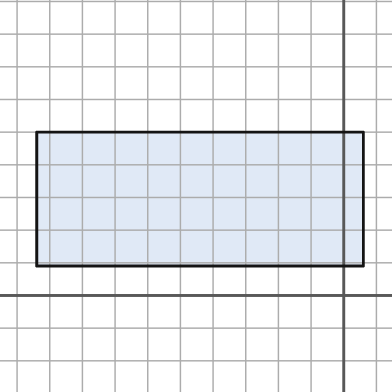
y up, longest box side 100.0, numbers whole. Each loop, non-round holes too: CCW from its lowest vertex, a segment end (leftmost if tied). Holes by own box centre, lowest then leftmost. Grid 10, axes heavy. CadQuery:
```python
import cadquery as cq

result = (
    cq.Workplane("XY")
    .moveTo(-94.0, 9.0)
    .lineTo(6.0, 9.0)
    .lineTo(6.0, 50.0)
    .lineTo(-94.0, 50.0)
    .close()
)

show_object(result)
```